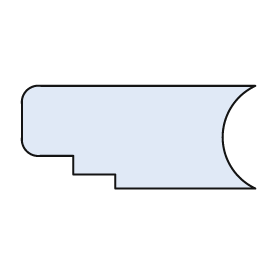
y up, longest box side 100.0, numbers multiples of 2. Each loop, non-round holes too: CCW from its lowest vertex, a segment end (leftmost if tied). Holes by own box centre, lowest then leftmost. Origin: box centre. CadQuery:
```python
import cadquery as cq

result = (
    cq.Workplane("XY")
    .moveTo(-10.0, -22.0)
    .lineTo(50.0, -22.0)
    .threePointArc((36.0, 0.0), (50.0, 22.0))
    .lineTo(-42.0, 22.0)
    .threePointArc((-48.0, 20.0), (-50.0, 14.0))
    .lineTo(-50.0, 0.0)
    .threePointArc((-48.0, -6.0), (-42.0, -8.0))
    .lineTo(-28.0, -8.0)
    .lineTo(-28.0, -16.0)
    .lineTo(-10.0, -16.0)
    .close()
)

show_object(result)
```